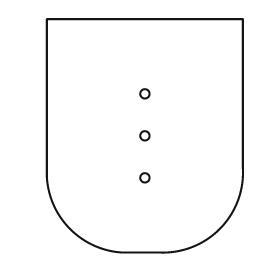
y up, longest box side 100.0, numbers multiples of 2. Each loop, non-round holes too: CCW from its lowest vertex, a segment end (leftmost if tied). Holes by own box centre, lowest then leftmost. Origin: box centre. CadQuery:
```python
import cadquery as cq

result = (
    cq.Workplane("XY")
    .moveTo(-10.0, -50.0)
    .lineTo(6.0, -50.0)
    .threePointArc((32.0, -40.0), (42.0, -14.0))
    .lineTo(42.0, 50.0)
    .lineTo(-42.0, 50.0)
    .lineTo(-42.0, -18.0)
    .threePointArc((-32.0, -40.0), (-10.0, -50.0))
    .close()
    .moveTo(0.0, -18.0)
    .circle(2.0)
    .moveTo(0.0, 0.0)
    .circle(2.0)
    .moveTo(0.0, 18.0)
    .circle(2.0)
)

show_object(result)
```